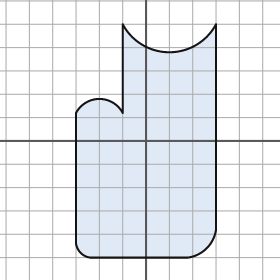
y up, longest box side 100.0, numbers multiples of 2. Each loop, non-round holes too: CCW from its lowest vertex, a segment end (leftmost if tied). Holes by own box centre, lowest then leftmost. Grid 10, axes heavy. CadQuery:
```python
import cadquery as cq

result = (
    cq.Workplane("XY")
    .moveTo(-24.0, -50.0)
    .lineTo(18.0, -50.0)
    .threePointArc((26.0, -46.0), (30.0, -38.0))
    .lineTo(30.0, 50.0)
    .threePointArc((10.0, 38.0), (-10.0, 50.0))
    .lineTo(-10.0, 12.0)
    .threePointArc((-20.0, 18.0), (-30.0, 12.0))
    .lineTo(-30.0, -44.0)
    .threePointArc((-28.0, -48.0), (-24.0, -50.0))
    .close()
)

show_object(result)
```